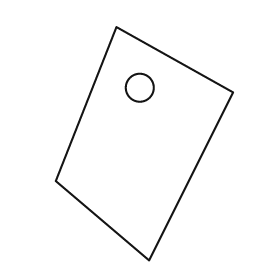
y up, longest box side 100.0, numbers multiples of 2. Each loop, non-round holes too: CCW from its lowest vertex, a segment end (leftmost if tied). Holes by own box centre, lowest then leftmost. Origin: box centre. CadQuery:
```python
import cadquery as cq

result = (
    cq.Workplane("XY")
    .moveTo(2.0, -50.0)
    .lineTo(38.0, 22.0)
    .lineTo(-12.0, 50.0)
    .lineTo(-38.0, -16.0)
    .close()
    .moveTo(-2.0, 24.0)
    .circle(6.0)
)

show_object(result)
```